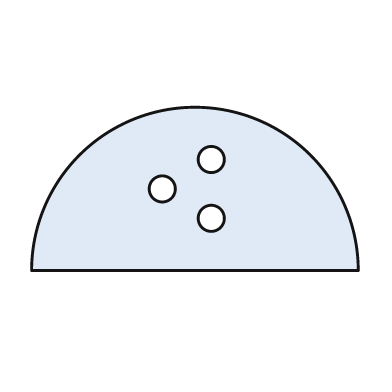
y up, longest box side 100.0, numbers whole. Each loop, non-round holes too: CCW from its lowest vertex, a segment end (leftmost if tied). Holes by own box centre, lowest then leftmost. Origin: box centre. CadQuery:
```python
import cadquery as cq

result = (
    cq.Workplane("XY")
    .moveTo(-50.0, -25.0)
    .lineTo(50.0, -25.0)
    .threePointArc((0.0, 25.0), (-50.0, -25.0))
    .close()
    .moveTo(5.0, -9.0)
    .circle(4.0)
    .moveTo(-10.0, 0.0)
    .circle(4.0)
    .moveTo(5.0, 9.0)
    .circle(4.0)
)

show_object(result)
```